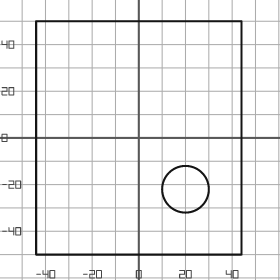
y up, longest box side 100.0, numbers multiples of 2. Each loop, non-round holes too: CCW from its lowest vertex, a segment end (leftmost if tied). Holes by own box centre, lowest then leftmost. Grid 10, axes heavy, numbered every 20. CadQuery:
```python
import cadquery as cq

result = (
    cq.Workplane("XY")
    .moveTo(-44.0, -50.0)
    .lineTo(44.0, -50.0)
    .lineTo(44.0, 50.0)
    .lineTo(-44.0, 50.0)
    .close()
    .moveTo(20.0, -22.0)
    .circle(10.0)
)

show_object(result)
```